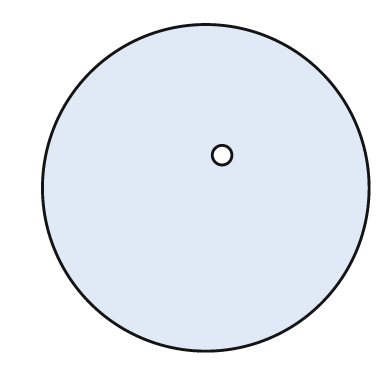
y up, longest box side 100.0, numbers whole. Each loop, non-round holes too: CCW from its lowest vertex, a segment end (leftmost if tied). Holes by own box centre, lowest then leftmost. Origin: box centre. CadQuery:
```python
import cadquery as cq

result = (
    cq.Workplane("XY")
    .moveTo(0.0, 0.0)
    .circle(50.0)
    .moveTo(5.0, 10.0)
    .circle(3.0)
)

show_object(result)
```